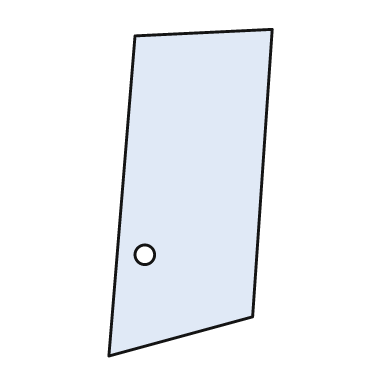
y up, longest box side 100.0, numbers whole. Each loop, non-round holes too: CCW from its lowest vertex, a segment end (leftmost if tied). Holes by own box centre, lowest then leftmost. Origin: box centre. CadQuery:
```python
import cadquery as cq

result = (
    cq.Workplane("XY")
    .moveTo(-25.0, -50.0)
    .lineTo(19.0, -38.0)
    .lineTo(25.0, 50.0)
    .lineTo(-17.0, 48.0)
    .close()
    .moveTo(-14.0, -19.0)
    .circle(3.0)
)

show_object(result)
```